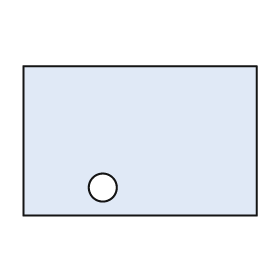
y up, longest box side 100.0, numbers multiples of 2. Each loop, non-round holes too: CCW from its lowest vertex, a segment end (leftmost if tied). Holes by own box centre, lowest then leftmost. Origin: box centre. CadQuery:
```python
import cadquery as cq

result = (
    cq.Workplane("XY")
    .moveTo(-50.0, -32.0)
    .lineTo(50.0, -32.0)
    .lineTo(50.0, 32.0)
    .lineTo(-50.0, 32.0)
    .close()
    .moveTo(-16.0, -20.0)
    .circle(6.0)
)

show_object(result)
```